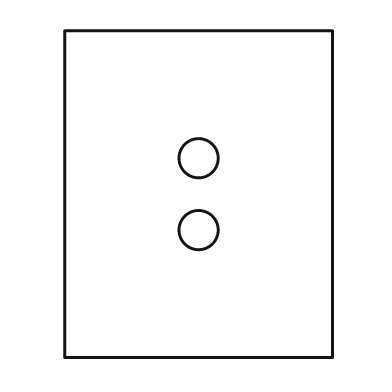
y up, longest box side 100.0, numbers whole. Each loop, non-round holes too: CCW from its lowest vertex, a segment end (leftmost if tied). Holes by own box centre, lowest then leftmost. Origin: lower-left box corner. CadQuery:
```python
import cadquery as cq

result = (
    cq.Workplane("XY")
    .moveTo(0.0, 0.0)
    .lineTo(82.0, 0.0)
    .lineTo(82.0, 100.0)
    .lineTo(0.0, 100.0)
    .close()
    .moveTo(41.0, 39.0)
    .circle(6.0)
    .moveTo(41.0, 61.0)
    .circle(6.0)
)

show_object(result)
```